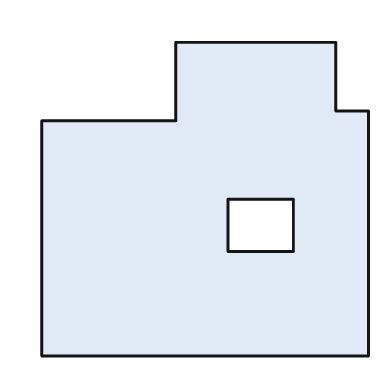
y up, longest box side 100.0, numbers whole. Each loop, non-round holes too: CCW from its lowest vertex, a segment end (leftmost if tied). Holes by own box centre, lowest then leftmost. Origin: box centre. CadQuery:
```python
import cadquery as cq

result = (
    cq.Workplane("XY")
    .moveTo(-50.0, -48.0)
    .lineTo(50.0, -48.0)
    .lineTo(50.0, 27.0)
    .lineTo(40.0, 27.0)
    .lineTo(40.0, 48.0)
    .lineTo(-9.0, 48.0)
    .lineTo(-9.0, 24.0)
    .lineTo(-50.0, 24.0)
    .close()
    .moveTo(7.0, -16.0)
    .lineTo(27.0, -16.0)
    .lineTo(27.0, 0.0)
    .lineTo(7.0, 0.0)
    .close()
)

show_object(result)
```